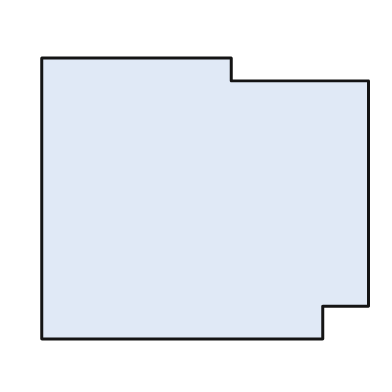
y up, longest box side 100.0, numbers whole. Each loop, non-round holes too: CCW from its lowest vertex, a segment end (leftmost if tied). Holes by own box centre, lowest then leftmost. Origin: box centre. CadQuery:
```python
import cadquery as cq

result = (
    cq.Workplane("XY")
    .moveTo(-50.0, -43.0)
    .lineTo(36.0, -43.0)
    .lineTo(36.0, -33.0)
    .lineTo(50.0, -33.0)
    .lineTo(50.0, 36.0)
    .lineTo(8.0, 36.0)
    .lineTo(8.0, 43.0)
    .lineTo(-50.0, 43.0)
    .close()
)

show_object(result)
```